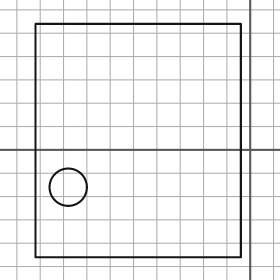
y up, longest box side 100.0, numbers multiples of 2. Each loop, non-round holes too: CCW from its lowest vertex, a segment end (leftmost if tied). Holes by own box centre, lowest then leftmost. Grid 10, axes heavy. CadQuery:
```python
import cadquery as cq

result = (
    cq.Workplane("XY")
    .moveTo(-92.0, -46.0)
    .lineTo(-4.0, -46.0)
    .lineTo(-4.0, 54.0)
    .lineTo(-92.0, 54.0)
    .close()
    .moveTo(-78.0, -16.0)
    .circle(8.0)
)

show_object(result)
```